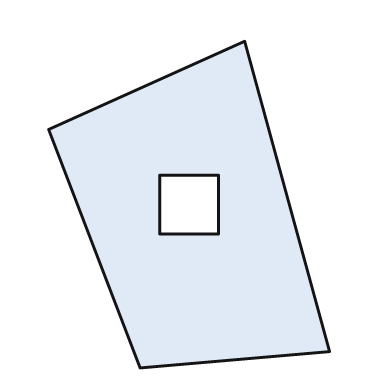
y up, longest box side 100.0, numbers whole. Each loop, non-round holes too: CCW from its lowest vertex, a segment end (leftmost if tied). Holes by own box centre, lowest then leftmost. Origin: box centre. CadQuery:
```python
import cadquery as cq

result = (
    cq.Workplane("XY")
    .moveTo(-15.0, -50.0)
    .lineTo(43.0, -45.0)
    .lineTo(17.0, 50.0)
    .lineTo(-43.0, 23.0)
    .close()
    .moveTo(-9.0, -9.0)
    .lineTo(9.0, -9.0)
    .lineTo(9.0, 9.0)
    .lineTo(-9.0, 9.0)
    .close()
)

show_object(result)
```